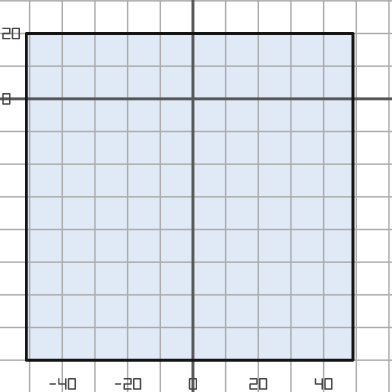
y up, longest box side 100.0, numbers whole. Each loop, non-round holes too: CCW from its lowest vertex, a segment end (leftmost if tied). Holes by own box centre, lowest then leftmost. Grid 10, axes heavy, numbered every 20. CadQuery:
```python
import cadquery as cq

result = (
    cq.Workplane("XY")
    .moveTo(-51.0, -80.0)
    .lineTo(49.0, -80.0)
    .lineTo(49.0, 20.0)
    .lineTo(-51.0, 20.0)
    .close()
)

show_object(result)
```